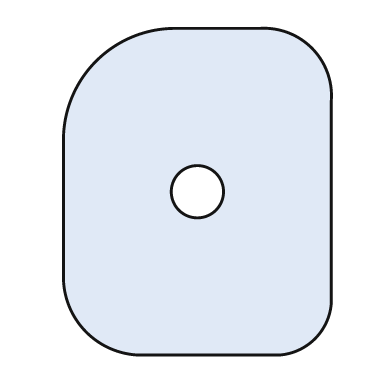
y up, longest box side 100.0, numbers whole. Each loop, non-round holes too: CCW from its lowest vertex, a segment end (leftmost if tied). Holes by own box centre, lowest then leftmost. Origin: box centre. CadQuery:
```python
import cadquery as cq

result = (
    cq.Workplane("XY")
    .moveTo(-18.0, -50.0)
    .lineTo(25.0, -50.0)
    .threePointArc((36.0, -45.0), (41.0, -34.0))
    .lineTo(41.0, 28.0)
    .threePointArc((35.0, 44.0), (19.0, 50.0))
    .lineTo(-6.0, 50.0)
    .threePointArc((-31.0, 40.0), (-41.0, 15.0))
    .lineTo(-41.0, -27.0)
    .threePointArc((-34.0, -43.0), (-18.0, -50.0))
    .close()
    .moveTo(0.0, 0.0)
    .circle(8.0)
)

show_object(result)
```